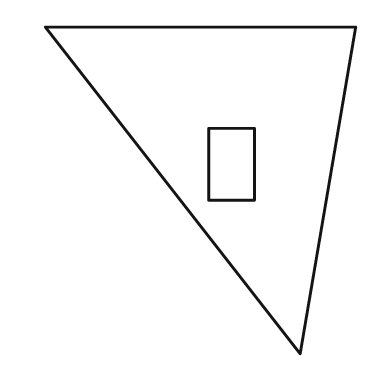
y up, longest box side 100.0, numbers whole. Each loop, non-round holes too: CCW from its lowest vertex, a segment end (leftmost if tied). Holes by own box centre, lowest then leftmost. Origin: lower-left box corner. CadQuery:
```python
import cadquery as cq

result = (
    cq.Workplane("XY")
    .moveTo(78.0, 0.0)
    .lineTo(95.0, 100.0)
    .lineTo(0.0, 100.0)
    .close()
    .moveTo(50.0, 47.0)
    .lineTo(64.0, 47.0)
    .lineTo(64.0, 69.0)
    .lineTo(50.0, 69.0)
    .close()
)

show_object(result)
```